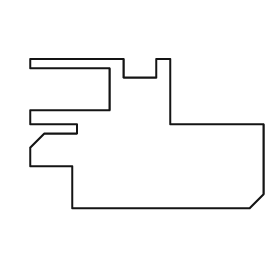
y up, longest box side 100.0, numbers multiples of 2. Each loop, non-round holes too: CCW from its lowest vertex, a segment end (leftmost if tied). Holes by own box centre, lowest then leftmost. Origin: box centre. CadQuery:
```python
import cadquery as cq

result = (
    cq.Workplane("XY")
    .moveTo(-32.0, -32.0)
    .lineTo(44.0, -32.0)
    .lineTo(50.0, -26.0)
    .lineTo(50.0, 4.0)
    .lineTo(10.0, 4.0)
    .lineTo(10.0, 32.0)
    .lineTo(4.0, 32.0)
    .lineTo(4.0, 24.0)
    .lineTo(-10.0, 24.0)
    .lineTo(-10.0, 32.0)
    .lineTo(-50.0, 32.0)
    .lineTo(-50.0, 28.0)
    .lineTo(-16.0, 28.0)
    .lineTo(-16.0, 10.0)
    .lineTo(-50.0, 10.0)
    .lineTo(-50.0, 4.0)
    .lineTo(-30.0, 4.0)
    .lineTo(-30.0, 0.0)
    .lineTo(-44.0, 0.0)
    .lineTo(-50.0, -6.0)
    .lineTo(-50.0, -14.0)
    .lineTo(-32.0, -14.0)
    .close()
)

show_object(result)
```